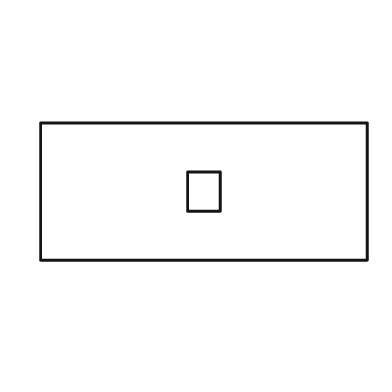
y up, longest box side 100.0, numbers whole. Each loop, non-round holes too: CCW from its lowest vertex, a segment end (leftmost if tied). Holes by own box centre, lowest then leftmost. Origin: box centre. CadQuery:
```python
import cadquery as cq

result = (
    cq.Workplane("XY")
    .moveTo(-50.0, -21.0)
    .lineTo(50.0, -21.0)
    .lineTo(50.0, 21.0)
    .lineTo(-50.0, 21.0)
    .close()
    .moveTo(-5.0, -6.0)
    .lineTo(5.0, -6.0)
    .lineTo(5.0, 6.0)
    .lineTo(-5.0, 6.0)
    .close()
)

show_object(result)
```